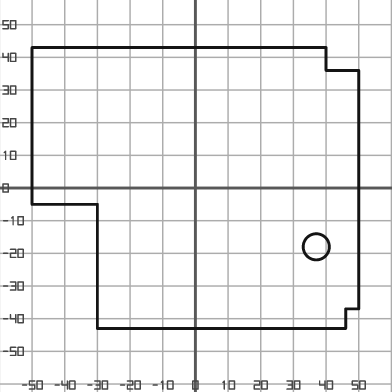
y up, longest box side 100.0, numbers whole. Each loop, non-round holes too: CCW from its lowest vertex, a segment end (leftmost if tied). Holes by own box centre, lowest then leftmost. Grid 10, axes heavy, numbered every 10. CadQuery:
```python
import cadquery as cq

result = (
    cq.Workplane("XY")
    .moveTo(-30.0, -43.0)
    .lineTo(46.0, -43.0)
    .lineTo(46.0, -37.0)
    .lineTo(50.0, -37.0)
    .lineTo(50.0, 36.0)
    .lineTo(40.0, 36.0)
    .lineTo(40.0, 43.0)
    .lineTo(-50.0, 43.0)
    .lineTo(-50.0, -5.0)
    .lineTo(-30.0, -5.0)
    .close()
    .moveTo(37.0, -18.0)
    .circle(4.0)
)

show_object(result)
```